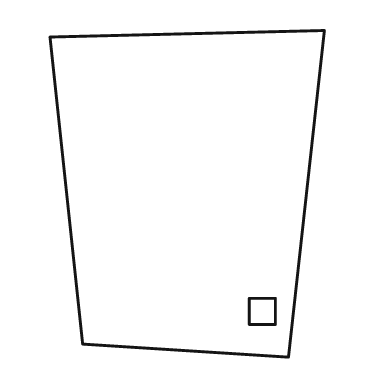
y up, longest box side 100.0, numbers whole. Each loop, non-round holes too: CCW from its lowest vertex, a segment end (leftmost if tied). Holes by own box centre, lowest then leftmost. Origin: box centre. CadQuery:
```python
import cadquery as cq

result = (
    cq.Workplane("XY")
    .moveTo(31.0, -50.0)
    .lineTo(42.0, 50.0)
    .lineTo(-42.0, 48.0)
    .lineTo(-32.0, -46.0)
    .close()
    .moveTo(19.0, -40.0)
    .lineTo(27.0, -40.0)
    .lineTo(27.0, -32.0)
    .lineTo(19.0, -32.0)
    .close()
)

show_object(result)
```